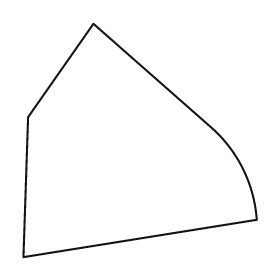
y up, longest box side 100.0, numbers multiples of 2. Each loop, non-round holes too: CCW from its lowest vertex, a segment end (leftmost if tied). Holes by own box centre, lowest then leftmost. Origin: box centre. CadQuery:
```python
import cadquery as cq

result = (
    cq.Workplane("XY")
    .moveTo(-50.0, -50.0)
    .lineTo(50.0, -34.0)
    .threePointArc((44.0, -12.0), (30.0, 6.0))
    .lineTo(-20.0, 50.0)
    .lineTo(-48.0, 10.0)
    .close()
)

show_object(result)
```